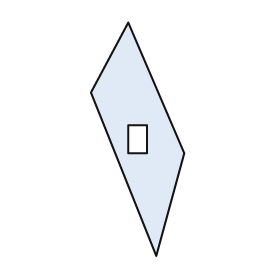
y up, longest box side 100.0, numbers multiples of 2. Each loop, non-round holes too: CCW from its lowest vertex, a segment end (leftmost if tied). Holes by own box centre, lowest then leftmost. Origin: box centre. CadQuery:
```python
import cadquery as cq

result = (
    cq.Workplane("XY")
    .moveTo(8.0, -50.0)
    .lineTo(20.0, -6.0)
    .lineTo(-4.0, 50.0)
    .lineTo(-20.0, 20.0)
    .close()
    .moveTo(-4.0, -6.0)
    .lineTo(4.0, -6.0)
    .lineTo(4.0, 6.0)
    .lineTo(-4.0, 6.0)
    .close()
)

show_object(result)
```